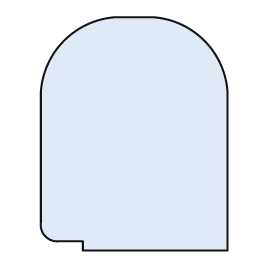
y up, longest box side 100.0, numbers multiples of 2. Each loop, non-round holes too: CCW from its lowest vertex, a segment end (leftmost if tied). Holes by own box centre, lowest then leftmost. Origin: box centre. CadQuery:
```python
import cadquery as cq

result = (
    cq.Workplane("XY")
    .moveTo(-22.0, -50.0)
    .lineTo(40.0, -50.0)
    .lineTo(40.0, 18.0)
    .threePointArc((30.0, 40.0), (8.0, 50.0))
    .lineTo(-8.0, 50.0)
    .threePointArc((-30.0, 40.0), (-40.0, 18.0))
    .lineTo(-40.0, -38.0)
    .threePointArc((-38.0, -44.0), (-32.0, -46.0))
    .lineTo(-22.0, -46.0)
    .close()
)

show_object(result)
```